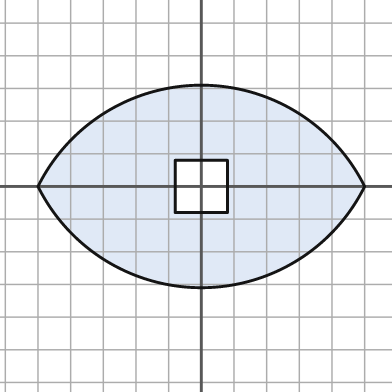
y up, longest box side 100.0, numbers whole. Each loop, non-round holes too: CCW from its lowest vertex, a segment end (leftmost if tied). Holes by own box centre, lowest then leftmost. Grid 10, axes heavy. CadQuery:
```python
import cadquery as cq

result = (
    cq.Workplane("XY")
    .moveTo(-50.0, 0.0)
    .threePointArc((0.0, -31.0), (50.0, 0.0))
    .threePointArc((0.0, 31.0), (-50.0, 0.0))
    .close()
    .moveTo(-8.0, -8.0)
    .lineTo(8.0, -8.0)
    .lineTo(8.0, 8.0)
    .lineTo(-8.0, 8.0)
    .close()
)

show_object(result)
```